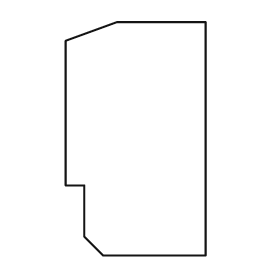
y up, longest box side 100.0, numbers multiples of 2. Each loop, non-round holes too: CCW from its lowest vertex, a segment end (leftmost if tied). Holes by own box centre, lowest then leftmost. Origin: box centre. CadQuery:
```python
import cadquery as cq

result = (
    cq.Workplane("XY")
    .moveTo(-14.0, -50.0)
    .lineTo(30.0, -50.0)
    .lineTo(30.0, 50.0)
    .lineTo(-8.0, 50.0)
    .lineTo(-30.0, 42.0)
    .lineTo(-30.0, -20.0)
    .lineTo(-22.0, -20.0)
    .lineTo(-22.0, -42.0)
    .close()
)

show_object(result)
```